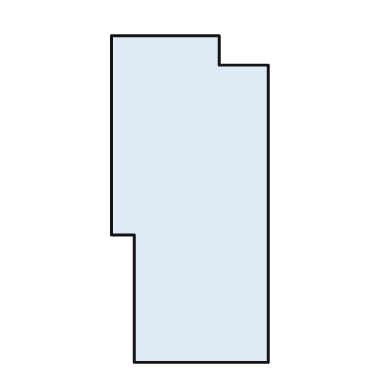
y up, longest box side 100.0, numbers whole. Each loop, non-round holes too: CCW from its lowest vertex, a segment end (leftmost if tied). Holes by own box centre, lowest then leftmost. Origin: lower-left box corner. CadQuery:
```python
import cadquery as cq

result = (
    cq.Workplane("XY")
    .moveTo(7.0, 0.0)
    .lineTo(48.0, 0.0)
    .lineTo(48.0, 91.0)
    .lineTo(33.0, 91.0)
    .lineTo(33.0, 100.0)
    .lineTo(0.0, 100.0)
    .lineTo(0.0, 39.0)
    .lineTo(7.0, 39.0)
    .close()
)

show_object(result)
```